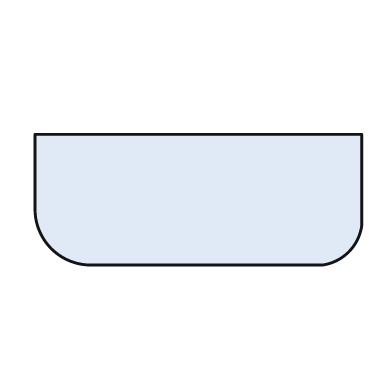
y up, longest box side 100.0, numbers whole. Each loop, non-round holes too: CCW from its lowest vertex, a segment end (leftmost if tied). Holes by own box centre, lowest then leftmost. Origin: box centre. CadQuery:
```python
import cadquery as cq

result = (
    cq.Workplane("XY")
    .moveTo(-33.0, -20.0)
    .lineTo(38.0, -20.0)
    .threePointArc((46.0, -16.0), (50.0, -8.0))
    .lineTo(50.0, 20.0)
    .lineTo(-50.0, 20.0)
    .lineTo(-50.0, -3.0)
    .threePointArc((-45.0, -15.0), (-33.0, -20.0))
    .close()
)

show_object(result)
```